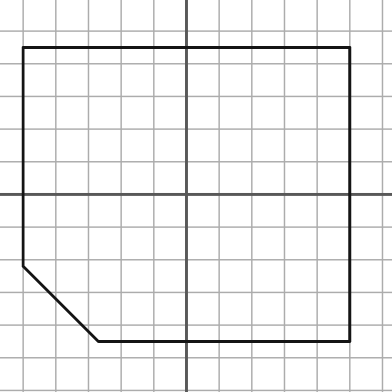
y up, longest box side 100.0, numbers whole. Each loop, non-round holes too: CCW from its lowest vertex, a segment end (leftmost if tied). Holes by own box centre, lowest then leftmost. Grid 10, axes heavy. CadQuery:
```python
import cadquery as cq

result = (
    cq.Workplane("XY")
    .moveTo(-27.0, -45.0)
    .lineTo(50.0, -45.0)
    .lineTo(50.0, 45.0)
    .lineTo(-50.0, 45.0)
    .lineTo(-50.0, -22.0)
    .close()
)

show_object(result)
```